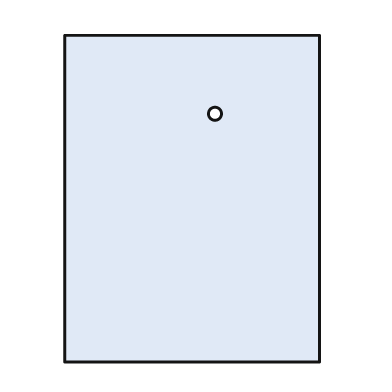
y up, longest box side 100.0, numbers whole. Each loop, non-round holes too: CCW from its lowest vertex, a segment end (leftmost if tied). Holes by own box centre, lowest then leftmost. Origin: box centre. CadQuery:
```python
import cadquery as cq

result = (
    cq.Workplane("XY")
    .moveTo(-39.0, -50.0)
    .lineTo(39.0, -50.0)
    .lineTo(39.0, 50.0)
    .lineTo(-39.0, 50.0)
    .close()
    .moveTo(7.0, 26.0)
    .circle(2.0)
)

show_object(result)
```